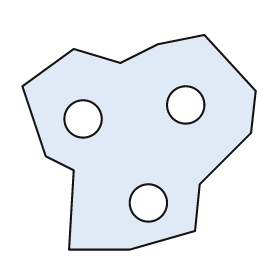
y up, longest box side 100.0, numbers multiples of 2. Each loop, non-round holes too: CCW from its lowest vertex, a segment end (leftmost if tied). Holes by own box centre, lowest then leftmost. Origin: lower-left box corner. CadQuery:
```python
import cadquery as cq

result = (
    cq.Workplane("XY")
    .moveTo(20.0, 0.0)
    .lineTo(46.0, 0.0)
    .lineTo(74.0, 8.0)
    .lineTo(76.0, 28.0)
    .lineTo(98.0, 50.0)
    .lineTo(100.0, 68.0)
    .lineTo(78.0, 92.0)
    .lineTo(58.0, 88.0)
    .lineTo(42.0, 80.0)
    .lineTo(22.0, 86.0)
    .lineTo(0.0, 70.0)
    .lineTo(10.0, 40.0)
    .lineTo(22.0, 34.0)
    .close()
    .moveTo(54.0, 20.0)
    .circle(8.0)
    .moveTo(26.0, 56.0)
    .circle(8.0)
    .moveTo(70.0, 62.0)
    .circle(8.0)
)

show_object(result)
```